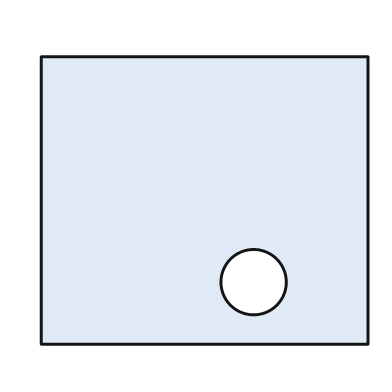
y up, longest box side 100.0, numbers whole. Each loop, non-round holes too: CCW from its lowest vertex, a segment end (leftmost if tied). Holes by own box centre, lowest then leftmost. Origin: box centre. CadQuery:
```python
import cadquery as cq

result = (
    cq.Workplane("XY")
    .moveTo(-50.0, -44.0)
    .lineTo(50.0, -44.0)
    .lineTo(50.0, 44.0)
    .lineTo(-50.0, 44.0)
    .close()
    .moveTo(15.0, -25.0)
    .circle(10.0)
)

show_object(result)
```